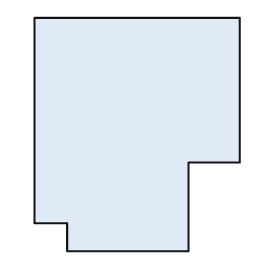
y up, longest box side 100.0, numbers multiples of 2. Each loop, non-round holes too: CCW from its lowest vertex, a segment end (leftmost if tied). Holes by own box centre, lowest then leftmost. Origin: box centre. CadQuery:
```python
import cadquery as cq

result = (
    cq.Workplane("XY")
    .moveTo(-30.0, -50.0)
    .lineTo(22.0, -50.0)
    .lineTo(22.0, -12.0)
    .lineTo(44.0, -12.0)
    .lineTo(44.0, 50.0)
    .lineTo(-44.0, 50.0)
    .lineTo(-44.0, -38.0)
    .lineTo(-30.0, -38.0)
    .close()
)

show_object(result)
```